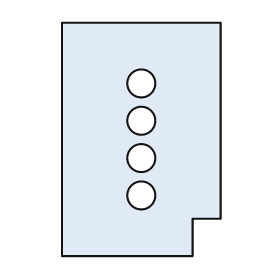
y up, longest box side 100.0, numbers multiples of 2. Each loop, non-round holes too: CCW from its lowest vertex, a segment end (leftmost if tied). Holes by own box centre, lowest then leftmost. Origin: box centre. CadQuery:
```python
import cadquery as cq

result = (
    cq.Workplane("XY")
    .moveTo(-34.0, -50.0)
    .lineTo(22.0, -50.0)
    .lineTo(22.0, -34.0)
    .lineTo(34.0, -34.0)
    .lineTo(34.0, 50.0)
    .lineTo(-34.0, 50.0)
    .close()
    .moveTo(0.0, -24.0)
    .circle(6.0)
    .moveTo(0.0, -8.0)
    .circle(6.0)
    .moveTo(0.0, 8.0)
    .circle(6.0)
    .moveTo(0.0, 24.0)
    .circle(6.0)
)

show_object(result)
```